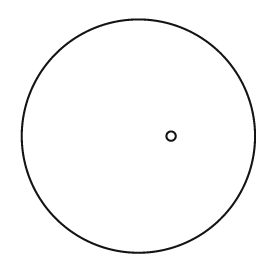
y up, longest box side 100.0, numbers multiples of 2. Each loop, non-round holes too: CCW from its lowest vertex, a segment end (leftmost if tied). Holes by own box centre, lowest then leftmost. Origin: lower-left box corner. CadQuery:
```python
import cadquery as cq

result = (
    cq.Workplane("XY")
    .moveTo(50.0, 50.0)
    .circle(50.0)
    .moveTo(64.0, 50.0)
    .circle(2.0)
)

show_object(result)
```